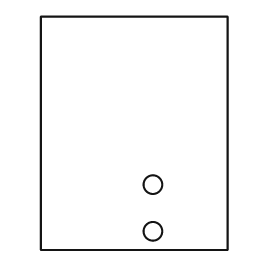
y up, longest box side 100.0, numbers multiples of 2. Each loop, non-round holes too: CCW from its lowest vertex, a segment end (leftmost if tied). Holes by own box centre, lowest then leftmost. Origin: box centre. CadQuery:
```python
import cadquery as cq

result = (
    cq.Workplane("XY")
    .moveTo(-40.0, -50.0)
    .lineTo(40.0, -50.0)
    .lineTo(40.0, 50.0)
    .lineTo(-40.0, 50.0)
    .close()
    .moveTo(8.0, -42.0)
    .circle(4.0)
    .moveTo(8.0, -22.0)
    .circle(4.0)
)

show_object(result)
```